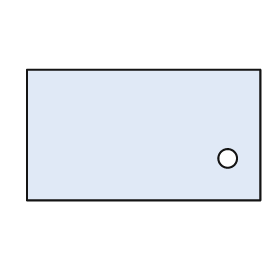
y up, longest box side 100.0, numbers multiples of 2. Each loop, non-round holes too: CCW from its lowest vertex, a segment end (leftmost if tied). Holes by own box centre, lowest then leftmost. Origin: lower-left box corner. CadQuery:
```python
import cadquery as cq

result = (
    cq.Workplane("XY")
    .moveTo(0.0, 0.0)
    .lineTo(100.0, 0.0)
    .lineTo(100.0, 56.0)
    .lineTo(0.0, 56.0)
    .close()
    .moveTo(86.0, 18.0)
    .circle(4.0)
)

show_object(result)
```